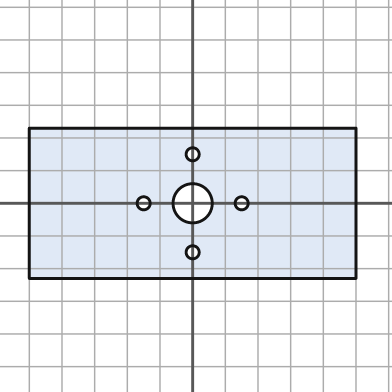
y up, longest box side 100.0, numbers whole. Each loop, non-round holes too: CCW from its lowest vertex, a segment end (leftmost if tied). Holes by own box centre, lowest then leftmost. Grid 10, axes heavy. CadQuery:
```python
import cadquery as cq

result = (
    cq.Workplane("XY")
    .moveTo(-50.0, -23.0)
    .lineTo(50.0, -23.0)
    .lineTo(50.0, 23.0)
    .lineTo(-50.0, 23.0)
    .close()
    .moveTo(0.0, -15.0)
    .circle(2.0)
    .moveTo(-15.0, 0.0)
    .circle(2.0)
    .moveTo(0.0, 0.0)
    .circle(6.0)
    .moveTo(15.0, 0.0)
    .circle(2.0)
    .moveTo(0.0, 15.0)
    .circle(2.0)
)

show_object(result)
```